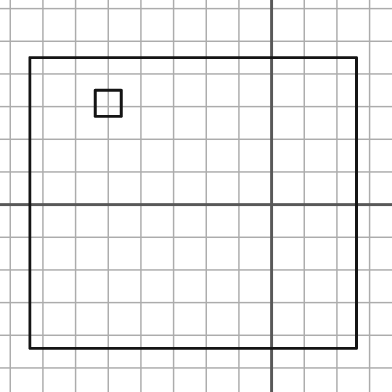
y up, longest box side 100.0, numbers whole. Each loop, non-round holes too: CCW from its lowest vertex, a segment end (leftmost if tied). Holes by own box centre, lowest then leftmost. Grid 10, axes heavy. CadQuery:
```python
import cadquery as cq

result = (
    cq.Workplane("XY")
    .moveTo(-74.0, -44.0)
    .lineTo(26.0, -44.0)
    .lineTo(26.0, 45.0)
    .lineTo(-74.0, 45.0)
    .close()
    .moveTo(-54.0, 27.0)
    .lineTo(-46.0, 27.0)
    .lineTo(-46.0, 35.0)
    .lineTo(-54.0, 35.0)
    .close()
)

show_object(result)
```